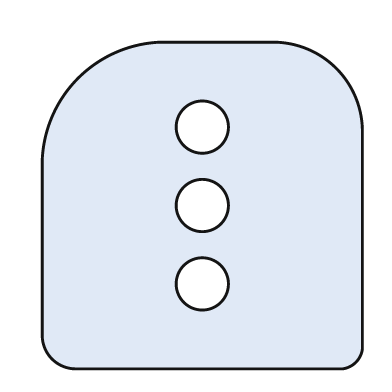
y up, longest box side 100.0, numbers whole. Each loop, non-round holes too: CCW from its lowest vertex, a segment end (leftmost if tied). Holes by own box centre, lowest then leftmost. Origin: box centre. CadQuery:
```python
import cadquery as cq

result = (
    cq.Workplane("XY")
    .moveTo(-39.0, -50.0)
    .lineTo(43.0, -50.0)
    .threePointArc((47.0, -48.0), (49.0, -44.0))
    .lineTo(49.0, 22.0)
    .threePointArc((41.0, 42.0), (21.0, 50.0))
    .lineTo(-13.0, 50.0)
    .threePointArc((-38.0, 39.0), (-49.0, 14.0))
    .lineTo(-49.0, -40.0)
    .threePointArc((-46.0, -47.0), (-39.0, -50.0))
    .close()
    .moveTo(0.0, -24.0)
    .circle(8.0)
    .moveTo(0.0, 0.0)
    .circle(8.0)
    .moveTo(0.0, 24.0)
    .circle(8.0)
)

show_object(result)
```